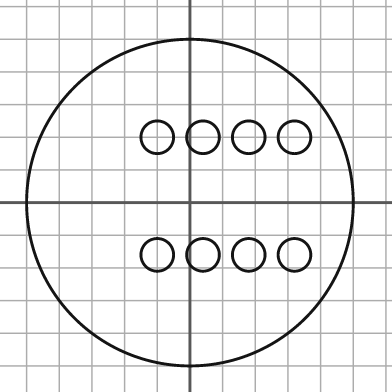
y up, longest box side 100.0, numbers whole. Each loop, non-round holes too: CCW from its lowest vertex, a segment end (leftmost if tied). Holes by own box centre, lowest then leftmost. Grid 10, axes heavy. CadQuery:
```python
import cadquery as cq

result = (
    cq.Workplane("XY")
    .moveTo(0.0, 0.0)
    .circle(50.0)
    .moveTo(-10.0, -16.0)
    .circle(5.0)
    .moveTo(4.0, -16.0)
    .circle(5.0)
    .moveTo(18.0, -16.0)
    .circle(5.0)
    .moveTo(32.0, -16.0)
    .circle(5.0)
    .moveTo(-10.0, 20.0)
    .circle(5.0)
    .moveTo(4.0, 20.0)
    .circle(5.0)
    .moveTo(18.0, 20.0)
    .circle(5.0)
    .moveTo(32.0, 20.0)
    .circle(5.0)
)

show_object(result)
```